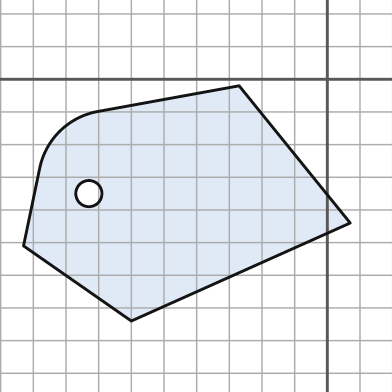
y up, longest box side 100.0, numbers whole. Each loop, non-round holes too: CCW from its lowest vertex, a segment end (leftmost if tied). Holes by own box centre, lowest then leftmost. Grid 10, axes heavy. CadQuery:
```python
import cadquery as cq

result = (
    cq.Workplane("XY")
    .moveTo(-60.0, -74.0)
    .lineTo(7.0, -44.0)
    .lineTo(-27.0, -2.0)
    .lineTo(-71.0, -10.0)
    .threePointArc((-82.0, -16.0), (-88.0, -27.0))
    .lineTo(-93.0, -51.0)
    .close()
    .moveTo(-73.0, -35.0)
    .circle(4.0)
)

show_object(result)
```